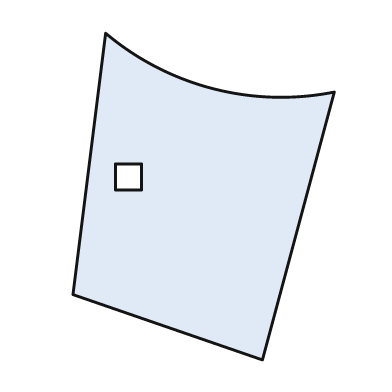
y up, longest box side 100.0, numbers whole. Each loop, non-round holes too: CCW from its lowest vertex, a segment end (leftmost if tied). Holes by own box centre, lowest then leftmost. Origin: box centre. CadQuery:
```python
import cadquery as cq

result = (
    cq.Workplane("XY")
    .moveTo(18.0, -50.0)
    .lineTo(40.0, 32.0)
    .threePointArc((3.0, 33.0), (-30.0, 50.0))
    .lineTo(-40.0, -30.0)
    .close()
    .moveTo(-27.0, 2.0)
    .lineTo(-19.0, 2.0)
    .lineTo(-19.0, 10.0)
    .lineTo(-27.0, 10.0)
    .close()
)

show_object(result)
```